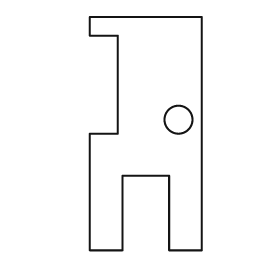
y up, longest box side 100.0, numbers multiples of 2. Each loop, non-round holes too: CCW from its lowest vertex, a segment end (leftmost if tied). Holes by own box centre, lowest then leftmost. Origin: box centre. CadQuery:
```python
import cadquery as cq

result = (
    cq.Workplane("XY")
    .moveTo(-24.0, -50.0)
    .lineTo(-10.0, -50.0)
    .lineTo(-10.0, -18.0)
    .lineTo(10.0, -18.0)
    .lineTo(10.0, -50.0)
    .lineTo(24.0, -50.0)
    .lineTo(24.0, 50.0)
    .lineTo(-24.0, 50.0)
    .lineTo(-24.0, 42.0)
    .lineTo(-12.0, 42.0)
    .lineTo(-12.0, 0.0)
    .lineTo(-24.0, 0.0)
    .close()
    .moveTo(14.0, 6.0)
    .circle(6.0)
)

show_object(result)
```